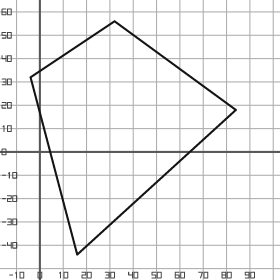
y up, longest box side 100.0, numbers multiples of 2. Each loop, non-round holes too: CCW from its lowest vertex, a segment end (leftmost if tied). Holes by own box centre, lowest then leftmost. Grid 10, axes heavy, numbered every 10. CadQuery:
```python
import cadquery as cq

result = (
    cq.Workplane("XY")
    .moveTo(16.0, -44.0)
    .lineTo(84.0, 18.0)
    .lineTo(32.0, 56.0)
    .lineTo(-4.0, 32.0)
    .close()
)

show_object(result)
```